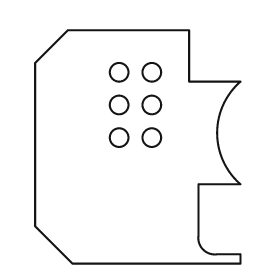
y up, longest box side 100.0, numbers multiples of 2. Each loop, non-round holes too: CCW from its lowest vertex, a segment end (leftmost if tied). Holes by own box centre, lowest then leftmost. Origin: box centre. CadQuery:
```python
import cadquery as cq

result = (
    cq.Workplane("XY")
    .moveTo(-28.0, -50.0)
    .lineTo(44.0, -50.0)
    .lineTo(44.0, -46.0)
    .lineTo(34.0, -46.0)
    .threePointArc((28.0, -44.0), (26.0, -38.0))
    .lineTo(26.0, -16.0)
    .lineTo(44.0, -16.0)
    .threePointArc((34.0, 6.0), (44.0, 28.0))
    .lineTo(22.0, 28.0)
    .lineTo(22.0, 50.0)
    .lineTo(-30.0, 50.0)
    .lineTo(-44.0, 36.0)
    .lineTo(-44.0, -34.0)
    .close()
    .moveTo(-8.0, 4.0)
    .circle(4.0)
    .moveTo(6.0, 4.0)
    .circle(4.0)
    .moveTo(-8.0, 18.0)
    .circle(4.0)
    .moveTo(6.0, 18.0)
    .circle(4.0)
    .moveTo(-8.0, 32.0)
    .circle(4.0)
    .moveTo(6.0, 32.0)
    .circle(4.0)
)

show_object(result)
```